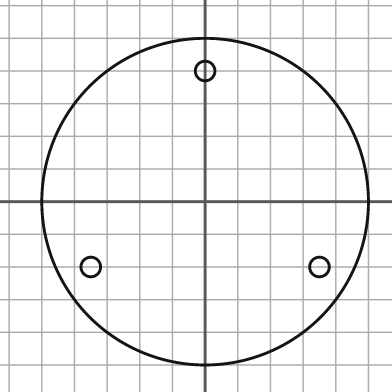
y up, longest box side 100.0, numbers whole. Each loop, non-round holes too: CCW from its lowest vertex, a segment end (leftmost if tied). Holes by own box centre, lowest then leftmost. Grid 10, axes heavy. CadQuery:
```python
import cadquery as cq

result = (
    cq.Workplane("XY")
    .moveTo(0.0, 0.0)
    .circle(50.0)
    .moveTo(-35.0, -20.0)
    .circle(3.0)
    .moveTo(35.0, -20.0)
    .circle(3.0)
    .moveTo(0.0, 40.0)
    .circle(3.0)
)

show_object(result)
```